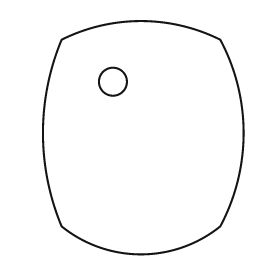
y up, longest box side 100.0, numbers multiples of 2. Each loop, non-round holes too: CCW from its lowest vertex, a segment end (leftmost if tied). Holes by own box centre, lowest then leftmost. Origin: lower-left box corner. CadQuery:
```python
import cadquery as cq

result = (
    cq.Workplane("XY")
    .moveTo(8.0, 12.0)
    .threePointArc((42.0, 0.0), (76.0, 12.0))
    .threePointArc((86.0, 52.0), (76.0, 92.0))
    .threePointArc((42.0, 100.0), (8.0, 92.0))
    .threePointArc((0.0, 52.0), (8.0, 12.0))
    .close()
    .moveTo(30.0, 74.0)
    .circle(6.0)
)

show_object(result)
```